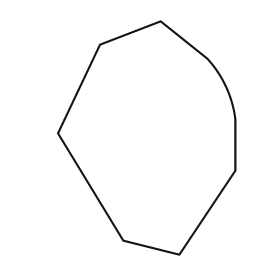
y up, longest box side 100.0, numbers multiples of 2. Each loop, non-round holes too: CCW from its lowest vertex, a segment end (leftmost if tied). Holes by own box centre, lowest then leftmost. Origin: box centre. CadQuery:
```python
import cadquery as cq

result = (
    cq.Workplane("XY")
    .moveTo(14.0, -50.0)
    .lineTo(38.0, -14.0)
    .lineTo(38.0, 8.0)
    .threePointArc((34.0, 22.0), (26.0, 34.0))
    .lineTo(6.0, 50.0)
    .lineTo(-20.0, 40.0)
    .lineTo(-38.0, 2.0)
    .lineTo(-10.0, -44.0)
    .close()
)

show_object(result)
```